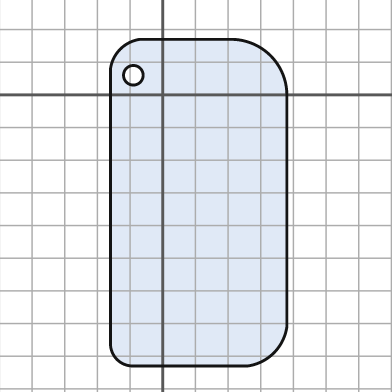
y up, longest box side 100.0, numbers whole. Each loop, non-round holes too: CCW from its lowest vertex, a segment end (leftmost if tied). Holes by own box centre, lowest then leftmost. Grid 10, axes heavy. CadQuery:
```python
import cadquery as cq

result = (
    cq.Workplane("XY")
    .moveTo(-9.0, -83.0)
    .lineTo(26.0, -83.0)
    .threePointArc((34.0, -79.0), (38.0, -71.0))
    .lineTo(38.0, 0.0)
    .threePointArc((33.0, 12.0), (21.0, 17.0))
    .lineTo(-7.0, 17.0)
    .threePointArc((-13.0, 14.0), (-16.0, 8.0))
    .lineTo(-16.0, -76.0)
    .threePointArc((-14.0, -81.0), (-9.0, -83.0))
    .close()
    .moveTo(-9.0, 6.0)
    .circle(3.0)
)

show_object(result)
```